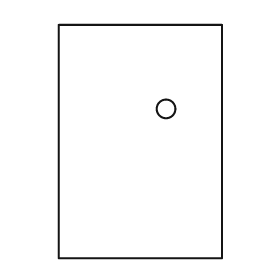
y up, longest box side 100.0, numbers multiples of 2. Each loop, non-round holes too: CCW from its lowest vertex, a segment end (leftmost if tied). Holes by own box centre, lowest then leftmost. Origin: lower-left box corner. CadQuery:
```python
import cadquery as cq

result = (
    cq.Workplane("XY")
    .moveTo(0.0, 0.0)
    .lineTo(70.0, 0.0)
    .lineTo(70.0, 100.0)
    .lineTo(0.0, 100.0)
    .close()
    .moveTo(46.0, 64.0)
    .circle(4.0)
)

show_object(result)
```